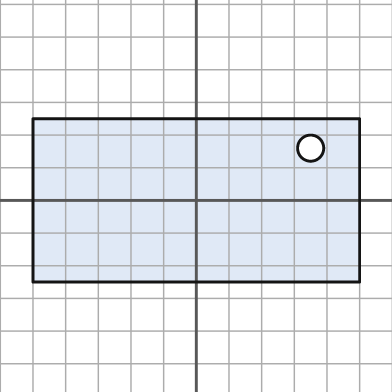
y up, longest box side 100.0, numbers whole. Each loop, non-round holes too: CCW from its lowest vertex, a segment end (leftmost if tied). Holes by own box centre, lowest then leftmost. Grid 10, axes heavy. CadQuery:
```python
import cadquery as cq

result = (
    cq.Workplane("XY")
    .moveTo(-50.0, -25.0)
    .lineTo(50.0, -25.0)
    .lineTo(50.0, 25.0)
    .lineTo(-50.0, 25.0)
    .close()
    .moveTo(35.0, 16.0)
    .circle(4.0)
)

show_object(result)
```